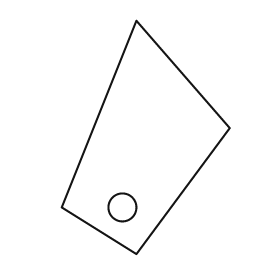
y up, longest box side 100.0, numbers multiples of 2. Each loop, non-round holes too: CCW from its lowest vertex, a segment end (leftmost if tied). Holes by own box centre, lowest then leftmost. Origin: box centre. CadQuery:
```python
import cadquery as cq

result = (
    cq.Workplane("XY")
    .moveTo(-4.0, -50.0)
    .lineTo(36.0, 4.0)
    .lineTo(-4.0, 50.0)
    .lineTo(-36.0, -30.0)
    .close()
    .moveTo(-10.0, -30.0)
    .circle(6.0)
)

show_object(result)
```